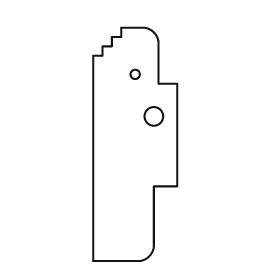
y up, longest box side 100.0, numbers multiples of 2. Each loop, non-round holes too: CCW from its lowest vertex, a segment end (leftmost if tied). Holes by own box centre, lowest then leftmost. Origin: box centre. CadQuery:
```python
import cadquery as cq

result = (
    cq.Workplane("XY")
    .moveTo(-18.0, -50.0)
    .lineTo(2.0, -50.0)
    .threePointArc((6.0, -48.0), (8.0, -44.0))
    .lineTo(8.0, -18.0)
    .lineTo(18.0, -18.0)
    .lineTo(18.0, 26.0)
    .lineTo(10.0, 26.0)
    .lineTo(10.0, 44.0)
    .threePointArc((8.0, 48.0), (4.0, 50.0))
    .lineTo(-6.0, 50.0)
    .lineTo(-6.0, 46.0)
    .lineTo(-10.0, 46.0)
    .lineTo(-10.0, 42.0)
    .lineTo(-14.0, 42.0)
    .lineTo(-14.0, 38.0)
    .lineTo(-18.0, 38.0)
    .close()
    .moveTo(8.0, 12.0)
    .circle(4.0)
    .moveTo(0.0, 30.0)
    .circle(2.0)
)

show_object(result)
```